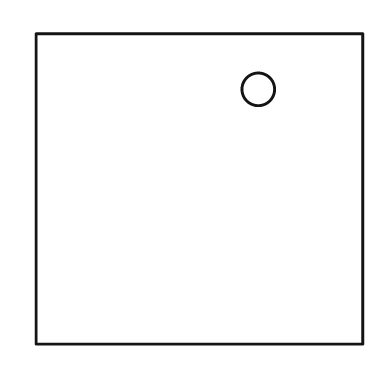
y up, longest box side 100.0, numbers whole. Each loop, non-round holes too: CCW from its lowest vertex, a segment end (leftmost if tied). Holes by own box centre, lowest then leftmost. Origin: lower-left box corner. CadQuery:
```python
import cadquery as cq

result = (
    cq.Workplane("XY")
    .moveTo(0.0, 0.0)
    .lineTo(100.0, 0.0)
    .lineTo(100.0, 95.0)
    .lineTo(0.0, 95.0)
    .close()
    .moveTo(68.0, 78.0)
    .circle(5.0)
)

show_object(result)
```